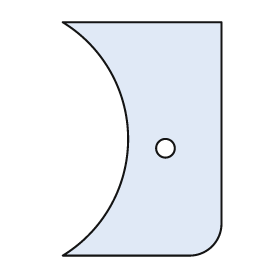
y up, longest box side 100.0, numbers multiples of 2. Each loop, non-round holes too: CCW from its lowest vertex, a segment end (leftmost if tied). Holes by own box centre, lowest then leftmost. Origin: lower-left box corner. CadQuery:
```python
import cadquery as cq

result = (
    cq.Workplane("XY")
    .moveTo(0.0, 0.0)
    .lineTo(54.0, 0.0)
    .threePointArc((64.0, 4.0), (68.0, 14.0))
    .lineTo(68.0, 100.0)
    .lineTo(0.0, 100.0)
    .threePointArc((28.0, 50.0), (0.0, 0.0))
    .close()
    .moveTo(44.0, 46.0)
    .circle(4.0)
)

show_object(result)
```